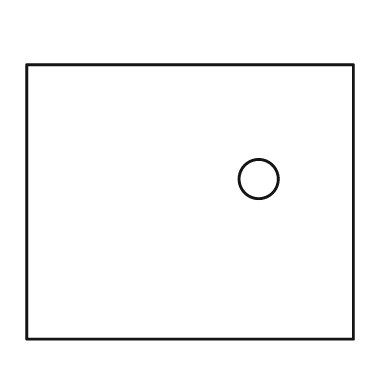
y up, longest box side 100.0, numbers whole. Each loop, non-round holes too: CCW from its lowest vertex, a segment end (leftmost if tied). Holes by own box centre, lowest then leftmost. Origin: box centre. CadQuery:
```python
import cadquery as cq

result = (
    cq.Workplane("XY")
    .moveTo(-50.0, -42.0)
    .lineTo(50.0, -42.0)
    .lineTo(50.0, 42.0)
    .lineTo(-50.0, 42.0)
    .close()
    .moveTo(21.0, 7.0)
    .circle(6.0)
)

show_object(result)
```